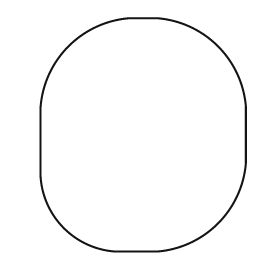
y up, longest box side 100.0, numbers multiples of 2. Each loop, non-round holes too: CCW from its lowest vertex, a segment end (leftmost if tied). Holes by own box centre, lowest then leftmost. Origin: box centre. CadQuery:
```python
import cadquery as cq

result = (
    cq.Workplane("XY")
    .moveTo(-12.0, -50.0)
    .lineTo(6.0, -50.0)
    .threePointArc((32.0, -38.0), (44.0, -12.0))
    .lineTo(44.0, 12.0)
    .threePointArc((32.0, 38.0), (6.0, 50.0))
    .lineTo(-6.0, 50.0)
    .threePointArc((-32.0, 38.0), (-44.0, 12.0))
    .lineTo(-44.0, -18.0)
    .threePointArc((-34.0, -40.0), (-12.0, -50.0))
    .close()
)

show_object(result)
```